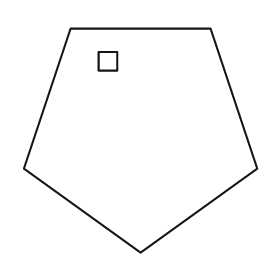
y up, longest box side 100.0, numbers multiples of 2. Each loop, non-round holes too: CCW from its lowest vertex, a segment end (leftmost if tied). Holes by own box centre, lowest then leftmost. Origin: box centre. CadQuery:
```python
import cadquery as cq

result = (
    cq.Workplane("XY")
    .moveTo(0.0, -48.0)
    .lineTo(50.0, -12.0)
    .lineTo(30.0, 48.0)
    .lineTo(-30.0, 48.0)
    .lineTo(-50.0, -12.0)
    .close()
    .moveTo(-18.0, 30.0)
    .lineTo(-10.0, 30.0)
    .lineTo(-10.0, 38.0)
    .lineTo(-18.0, 38.0)
    .close()
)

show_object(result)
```